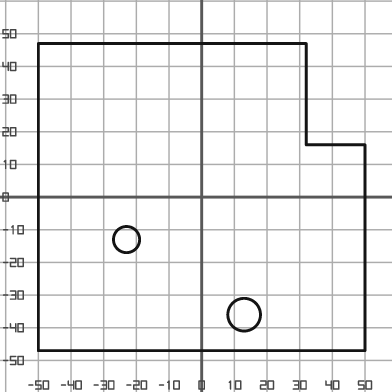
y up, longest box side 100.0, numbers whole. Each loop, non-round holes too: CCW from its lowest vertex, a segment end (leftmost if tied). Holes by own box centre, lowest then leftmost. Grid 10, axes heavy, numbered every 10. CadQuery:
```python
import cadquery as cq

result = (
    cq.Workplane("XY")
    .moveTo(-50.0, -47.0)
    .lineTo(50.0, -47.0)
    .lineTo(50.0, 16.0)
    .lineTo(32.0, 16.0)
    .lineTo(32.0, 47.0)
    .lineTo(-50.0, 47.0)
    .close()
    .moveTo(13.0, -36.0)
    .circle(5.0)
    .moveTo(-23.0, -13.0)
    .circle(4.0)
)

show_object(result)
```